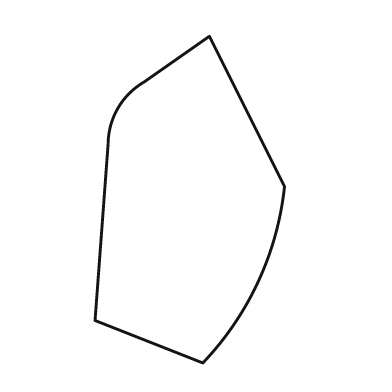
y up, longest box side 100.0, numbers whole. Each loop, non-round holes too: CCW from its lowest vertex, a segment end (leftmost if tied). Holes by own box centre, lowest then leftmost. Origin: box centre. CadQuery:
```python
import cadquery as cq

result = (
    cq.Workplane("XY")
    .moveTo(4.0, -50.0)
    .threePointArc((21.0, -25.0), (29.0, 4.0))
    .lineTo(6.0, 50.0)
    .lineTo(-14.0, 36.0)
    .threePointArc((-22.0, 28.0), (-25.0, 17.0))
    .lineTo(-29.0, -37.0)
    .close()
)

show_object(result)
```